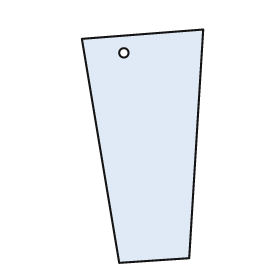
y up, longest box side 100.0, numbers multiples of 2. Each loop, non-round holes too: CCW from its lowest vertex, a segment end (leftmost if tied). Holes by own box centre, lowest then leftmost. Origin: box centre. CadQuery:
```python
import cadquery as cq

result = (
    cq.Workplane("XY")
    .moveTo(-10.0, -50.0)
    .lineTo(20.0, -48.0)
    .lineTo(26.0, 50.0)
    .lineTo(-26.0, 46.0)
    .close()
    .moveTo(-8.0, 40.0)
    .circle(2.0)
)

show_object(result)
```